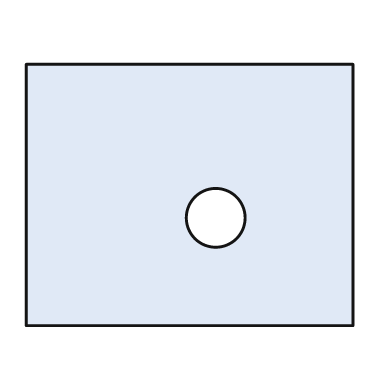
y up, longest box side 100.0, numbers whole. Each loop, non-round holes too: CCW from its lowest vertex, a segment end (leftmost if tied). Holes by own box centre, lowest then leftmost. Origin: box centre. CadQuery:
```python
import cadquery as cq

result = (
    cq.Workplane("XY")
    .moveTo(-50.0, -40.0)
    .lineTo(50.0, -40.0)
    .lineTo(50.0, 40.0)
    .lineTo(-50.0, 40.0)
    .close()
    .moveTo(8.0, -7.0)
    .circle(9.0)
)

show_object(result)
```